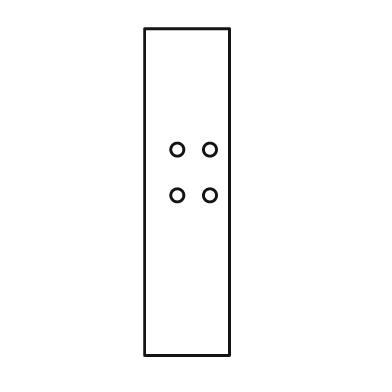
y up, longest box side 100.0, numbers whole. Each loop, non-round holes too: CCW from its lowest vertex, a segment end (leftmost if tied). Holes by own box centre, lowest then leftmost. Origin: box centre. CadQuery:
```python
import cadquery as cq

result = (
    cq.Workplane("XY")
    .moveTo(-13.0, -50.0)
    .lineTo(13.0, -50.0)
    .lineTo(13.0, 50.0)
    .lineTo(-13.0, 50.0)
    .close()
    .moveTo(-3.0, -1.0)
    .circle(2.0)
    .moveTo(7.0, -1.0)
    .circle(2.0)
    .moveTo(-3.0, 13.0)
    .circle(2.0)
    .moveTo(7.0, 13.0)
    .circle(2.0)
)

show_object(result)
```